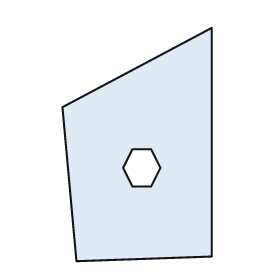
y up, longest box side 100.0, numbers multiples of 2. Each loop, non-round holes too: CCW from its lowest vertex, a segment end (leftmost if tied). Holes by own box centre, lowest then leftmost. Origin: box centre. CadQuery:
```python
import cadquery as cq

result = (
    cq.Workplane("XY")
    .moveTo(-26.0, -50.0)
    .lineTo(32.0, -48.0)
    .lineTo(32.0, 50.0)
    .lineTo(-32.0, 16.0)
    .close()
    .moveTo(-2.0, -18.0)
    .lineTo(6.0, -18.0)
    .lineTo(10.0, -10.0)
    .lineTo(6.0, -2.0)
    .lineTo(-2.0, -2.0)
    .lineTo(-6.0, -10.0)
    .close()
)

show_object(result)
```